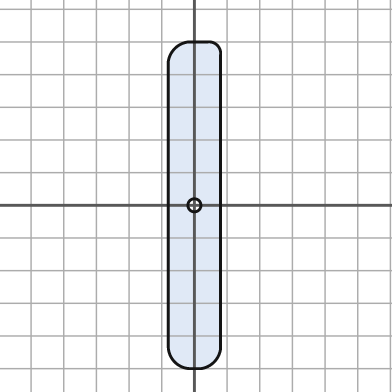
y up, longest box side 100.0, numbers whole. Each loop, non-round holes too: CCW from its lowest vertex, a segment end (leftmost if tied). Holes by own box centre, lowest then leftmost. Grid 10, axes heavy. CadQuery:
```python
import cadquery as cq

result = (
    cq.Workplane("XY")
    .moveTo(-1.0, -50.0)
    .lineTo(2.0, -50.0)
    .threePointArc((6.0, -48.0), (8.0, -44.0))
    .lineTo(8.0, 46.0)
    .threePointArc((7.0, 49.0), (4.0, 50.0))
    .lineTo(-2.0, 50.0)
    .threePointArc((-6.0, 48.0), (-8.0, 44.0))
    .lineTo(-8.0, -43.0)
    .threePointArc((-6.0, -48.0), (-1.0, -50.0))
    .close()
    .moveTo(0.0, 0.0)
    .circle(2.0)
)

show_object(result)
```